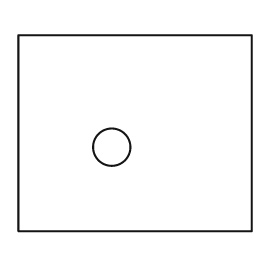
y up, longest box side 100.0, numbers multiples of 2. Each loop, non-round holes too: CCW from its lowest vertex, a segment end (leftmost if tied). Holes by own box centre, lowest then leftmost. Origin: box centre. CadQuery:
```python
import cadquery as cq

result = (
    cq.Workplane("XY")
    .moveTo(-50.0, -42.0)
    .lineTo(50.0, -42.0)
    .lineTo(50.0, 42.0)
    .lineTo(-50.0, 42.0)
    .close()
    .moveTo(-10.0, -6.0)
    .circle(8.0)
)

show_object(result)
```